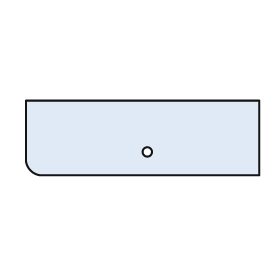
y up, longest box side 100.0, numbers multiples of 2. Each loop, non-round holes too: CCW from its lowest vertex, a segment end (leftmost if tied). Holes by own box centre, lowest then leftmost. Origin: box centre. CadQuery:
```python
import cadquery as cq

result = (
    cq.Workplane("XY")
    .moveTo(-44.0, -16.0)
    .lineTo(50.0, -16.0)
    .lineTo(50.0, 16.0)
    .lineTo(-50.0, 16.0)
    .lineTo(-50.0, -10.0)
    .threePointArc((-48.0, -14.0), (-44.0, -16.0))
    .close()
    .moveTo(2.0, -6.0)
    .circle(2.0)
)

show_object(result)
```